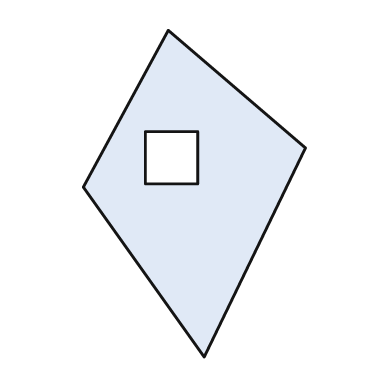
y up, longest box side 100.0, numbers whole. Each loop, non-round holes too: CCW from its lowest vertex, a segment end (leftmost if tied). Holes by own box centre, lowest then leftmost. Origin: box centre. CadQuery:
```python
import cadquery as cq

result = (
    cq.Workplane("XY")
    .moveTo(3.0, -50.0)
    .lineTo(34.0, 14.0)
    .lineTo(-8.0, 50.0)
    .lineTo(-34.0, 2.0)
    .close()
    .moveTo(-15.0, 3.0)
    .lineTo(1.0, 3.0)
    .lineTo(1.0, 19.0)
    .lineTo(-15.0, 19.0)
    .close()
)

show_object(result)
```